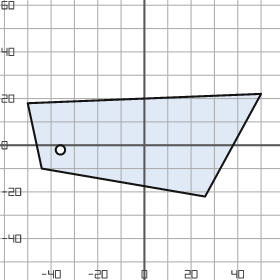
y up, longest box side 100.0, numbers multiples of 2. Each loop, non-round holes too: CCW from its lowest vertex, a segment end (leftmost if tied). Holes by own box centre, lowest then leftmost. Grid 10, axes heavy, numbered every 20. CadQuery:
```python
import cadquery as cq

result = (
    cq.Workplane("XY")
    .moveTo(26.0, -22.0)
    .lineTo(50.0, 22.0)
    .lineTo(-50.0, 18.0)
    .lineTo(-44.0, -10.0)
    .close()
    .moveTo(-36.0, -2.0)
    .circle(2.0)
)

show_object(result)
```